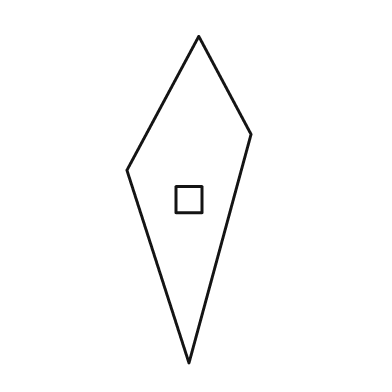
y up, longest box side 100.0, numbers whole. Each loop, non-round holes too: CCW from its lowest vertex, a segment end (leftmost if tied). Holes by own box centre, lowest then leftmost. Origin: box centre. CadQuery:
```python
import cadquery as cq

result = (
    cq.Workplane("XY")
    .moveTo(0.0, -50.0)
    .lineTo(19.0, 20.0)
    .lineTo(3.0, 50.0)
    .lineTo(-19.0, 9.0)
    .close()
    .moveTo(-4.0, -4.0)
    .lineTo(4.0, -4.0)
    .lineTo(4.0, 4.0)
    .lineTo(-4.0, 4.0)
    .close()
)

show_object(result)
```